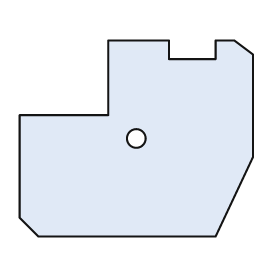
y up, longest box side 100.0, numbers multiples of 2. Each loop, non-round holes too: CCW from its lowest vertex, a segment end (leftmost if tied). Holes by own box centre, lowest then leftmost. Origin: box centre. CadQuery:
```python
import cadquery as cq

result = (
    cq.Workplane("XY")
    .moveTo(-42.0, -42.0)
    .lineTo(34.0, -42.0)
    .lineTo(50.0, -8.0)
    .lineTo(50.0, 36.0)
    .lineTo(42.0, 42.0)
    .lineTo(34.0, 42.0)
    .lineTo(34.0, 34.0)
    .lineTo(14.0, 34.0)
    .lineTo(14.0, 42.0)
    .lineTo(-12.0, 42.0)
    .lineTo(-12.0, 10.0)
    .lineTo(-50.0, 10.0)
    .lineTo(-50.0, -34.0)
    .close()
    .moveTo(0.0, 0.0)
    .circle(4.0)
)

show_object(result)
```